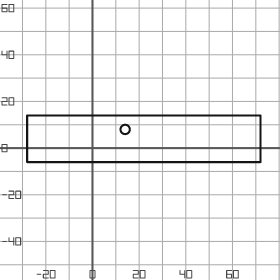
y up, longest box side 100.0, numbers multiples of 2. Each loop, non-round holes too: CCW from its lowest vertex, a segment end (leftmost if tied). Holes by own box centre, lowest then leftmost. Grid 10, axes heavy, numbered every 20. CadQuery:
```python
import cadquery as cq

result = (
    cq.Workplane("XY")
    .moveTo(-28.0, -6.0)
    .lineTo(72.0, -6.0)
    .lineTo(72.0, 14.0)
    .lineTo(-28.0, 14.0)
    .close()
    .moveTo(14.0, 8.0)
    .circle(2.0)
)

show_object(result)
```